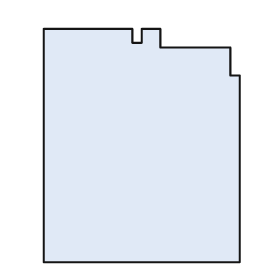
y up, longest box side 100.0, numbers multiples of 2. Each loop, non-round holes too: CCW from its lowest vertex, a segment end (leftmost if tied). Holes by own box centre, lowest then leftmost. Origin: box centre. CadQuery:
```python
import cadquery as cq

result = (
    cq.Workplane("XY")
    .moveTo(-42.0, -50.0)
    .lineTo(42.0, -50.0)
    .lineTo(42.0, 30.0)
    .lineTo(38.0, 30.0)
    .lineTo(38.0, 42.0)
    .lineTo(8.0, 42.0)
    .lineTo(8.0, 50.0)
    .lineTo(0.0, 50.0)
    .lineTo(0.0, 44.0)
    .lineTo(-4.0, 44.0)
    .lineTo(-4.0, 50.0)
    .lineTo(-42.0, 50.0)
    .close()
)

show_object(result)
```